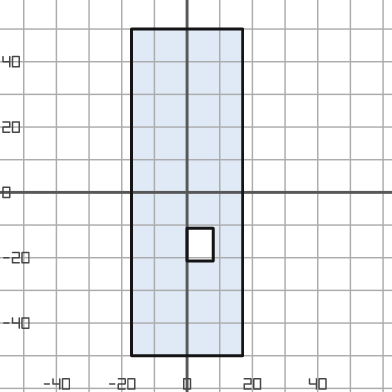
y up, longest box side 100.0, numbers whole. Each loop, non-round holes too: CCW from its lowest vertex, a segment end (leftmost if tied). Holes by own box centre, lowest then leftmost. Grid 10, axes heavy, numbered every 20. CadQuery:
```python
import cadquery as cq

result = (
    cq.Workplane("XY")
    .moveTo(-17.0, -50.0)
    .lineTo(17.0, -50.0)
    .lineTo(17.0, 50.0)
    .lineTo(-17.0, 50.0)
    .close()
    .moveTo(0.0, -21.0)
    .lineTo(8.0, -21.0)
    .lineTo(8.0, -11.0)
    .lineTo(0.0, -11.0)
    .close()
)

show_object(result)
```